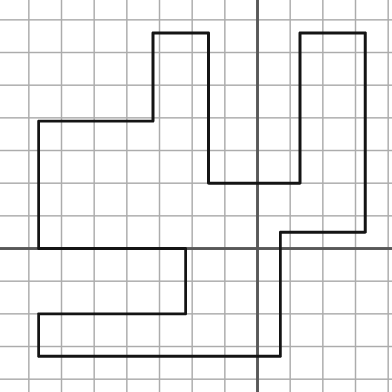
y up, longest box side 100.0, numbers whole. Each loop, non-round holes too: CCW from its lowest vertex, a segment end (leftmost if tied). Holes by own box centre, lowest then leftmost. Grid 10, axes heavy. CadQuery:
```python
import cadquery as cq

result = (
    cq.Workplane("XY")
    .moveTo(-67.0, -33.0)
    .lineTo(7.0, -33.0)
    .lineTo(7.0, 5.0)
    .lineTo(33.0, 5.0)
    .lineTo(33.0, 66.0)
    .lineTo(13.0, 66.0)
    .lineTo(13.0, 20.0)
    .lineTo(-15.0, 20.0)
    .lineTo(-15.0, 66.0)
    .lineTo(-32.0, 66.0)
    .lineTo(-32.0, 39.0)
    .lineTo(-67.0, 39.0)
    .lineTo(-67.0, 0.0)
    .lineTo(-22.0, 0.0)
    .lineTo(-22.0, -20.0)
    .lineTo(-67.0, -20.0)
    .close()
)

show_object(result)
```